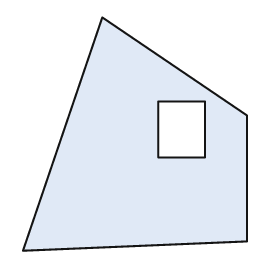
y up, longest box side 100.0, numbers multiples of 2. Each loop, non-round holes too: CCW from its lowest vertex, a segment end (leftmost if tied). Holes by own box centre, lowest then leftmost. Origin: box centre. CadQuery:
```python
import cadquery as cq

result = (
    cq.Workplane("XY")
    .moveTo(-48.0, -50.0)
    .lineTo(48.0, -46.0)
    .lineTo(48.0, 8.0)
    .lineTo(-14.0, 50.0)
    .close()
    .moveTo(10.0, -10.0)
    .lineTo(30.0, -10.0)
    .lineTo(30.0, 14.0)
    .lineTo(10.0, 14.0)
    .close()
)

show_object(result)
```